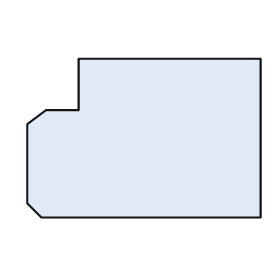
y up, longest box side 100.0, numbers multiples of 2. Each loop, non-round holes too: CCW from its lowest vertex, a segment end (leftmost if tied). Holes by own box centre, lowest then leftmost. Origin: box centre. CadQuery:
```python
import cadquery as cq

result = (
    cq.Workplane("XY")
    .moveTo(-44.0, -34.0)
    .lineTo(50.0, -34.0)
    .lineTo(50.0, 34.0)
    .lineTo(-28.0, 34.0)
    .lineTo(-28.0, 12.0)
    .lineTo(-42.0, 12.0)
    .lineTo(-50.0, 6.0)
    .lineTo(-50.0, -28.0)
    .close()
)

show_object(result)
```